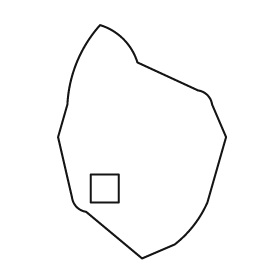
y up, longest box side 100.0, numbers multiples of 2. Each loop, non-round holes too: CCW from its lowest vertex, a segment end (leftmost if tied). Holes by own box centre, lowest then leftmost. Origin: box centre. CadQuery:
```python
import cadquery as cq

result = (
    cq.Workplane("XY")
    .moveTo(0.0, -50.0)
    .lineTo(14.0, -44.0)
    .threePointArc((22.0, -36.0), (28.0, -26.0))
    .lineTo(36.0, 2.0)
    .lineTo(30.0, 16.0)
    .threePointArc((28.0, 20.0), (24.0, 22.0))
    .lineTo(-2.0, 34.0)
    .threePointArc((-8.0, 44.0), (-18.0, 50.0))
    .threePointArc((-28.0, 34.0), (-32.0, 16.0))
    .lineTo(-36.0, 2.0)
    .lineTo(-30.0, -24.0)
    .threePointArc((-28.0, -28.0), (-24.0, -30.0))
    .close()
    .moveTo(-22.0, -26.0)
    .lineTo(-10.0, -26.0)
    .lineTo(-10.0, -14.0)
    .lineTo(-22.0, -14.0)
    .close()
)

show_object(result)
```